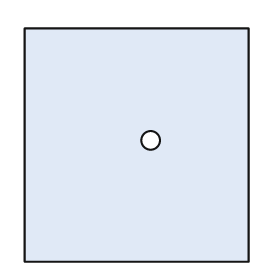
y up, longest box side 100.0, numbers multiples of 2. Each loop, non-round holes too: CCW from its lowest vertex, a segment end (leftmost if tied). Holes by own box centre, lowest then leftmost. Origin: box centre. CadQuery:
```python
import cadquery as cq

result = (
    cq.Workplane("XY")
    .moveTo(-48.0, -50.0)
    .lineTo(48.0, -50.0)
    .lineTo(48.0, 50.0)
    .lineTo(-48.0, 50.0)
    .close()
    .moveTo(6.0, 2.0)
    .circle(4.0)
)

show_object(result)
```